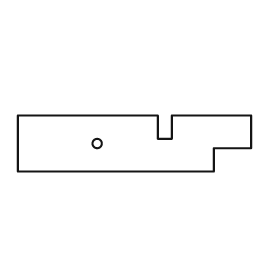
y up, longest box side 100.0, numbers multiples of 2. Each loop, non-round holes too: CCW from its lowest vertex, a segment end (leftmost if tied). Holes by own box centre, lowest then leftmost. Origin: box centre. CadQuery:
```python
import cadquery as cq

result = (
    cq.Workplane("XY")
    .moveTo(-50.0, -12.0)
    .lineTo(34.0, -12.0)
    .lineTo(34.0, -2.0)
    .lineTo(50.0, -2.0)
    .lineTo(50.0, 12.0)
    .lineTo(16.0, 12.0)
    .lineTo(16.0, 2.0)
    .lineTo(10.0, 2.0)
    .lineTo(10.0, 12.0)
    .lineTo(-50.0, 12.0)
    .close()
    .moveTo(-16.0, 0.0)
    .circle(2.0)
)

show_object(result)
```